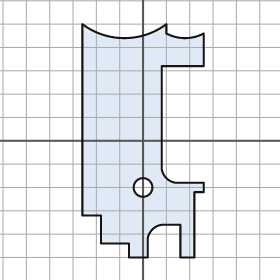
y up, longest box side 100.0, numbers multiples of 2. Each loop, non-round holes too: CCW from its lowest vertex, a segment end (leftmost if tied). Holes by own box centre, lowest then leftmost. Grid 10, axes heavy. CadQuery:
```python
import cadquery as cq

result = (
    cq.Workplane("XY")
    .moveTo(-6.0, -50.0)
    .lineTo(2.0, -50.0)
    .lineTo(2.0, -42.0)
    .threePointArc((4.0, -38.0), (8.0, -36.0))
    .lineTo(16.0, -36.0)
    .lineTo(16.0, -50.0)
    .lineTo(22.0, -50.0)
    .lineTo(22.0, -22.0)
    .lineTo(26.0, -22.0)
    .lineTo(26.0, -18.0)
    .lineTo(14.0, -18.0)
    .threePointArc((10.0, -16.0), (8.0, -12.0))
    .lineTo(8.0, 32.0)
    .lineTo(26.0, 32.0)
    .lineTo(26.0, 46.0)
    .threePointArc((18.0, 44.0), (10.0, 46.0))
    .lineTo(10.0, 50.0)
    .threePointArc((-8.0, 44.0), (-26.0, 50.0))
    .lineTo(-26.0, -32.0)
    .lineTo(-18.0, -32.0)
    .lineTo(-18.0, -44.0)
    .lineTo(-6.0, -44.0)
    .close()
    .moveTo(0.0, -20.0)
    .circle(4.0)
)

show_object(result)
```